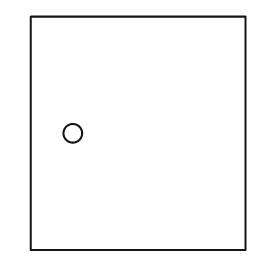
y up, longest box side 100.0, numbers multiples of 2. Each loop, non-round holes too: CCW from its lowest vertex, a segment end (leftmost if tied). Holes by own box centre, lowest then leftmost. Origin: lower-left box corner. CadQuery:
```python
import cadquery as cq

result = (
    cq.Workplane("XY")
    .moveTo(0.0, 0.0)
    .lineTo(92.0, 0.0)
    .lineTo(92.0, 100.0)
    .lineTo(0.0, 100.0)
    .close()
    .moveTo(18.0, 50.0)
    .circle(4.0)
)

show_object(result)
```